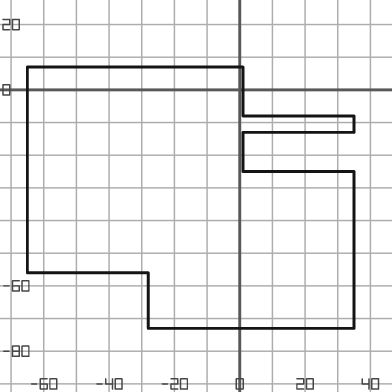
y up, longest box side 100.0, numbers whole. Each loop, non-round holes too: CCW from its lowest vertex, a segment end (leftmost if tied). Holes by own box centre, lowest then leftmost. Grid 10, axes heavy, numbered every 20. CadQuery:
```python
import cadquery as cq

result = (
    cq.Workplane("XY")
    .moveTo(-28.0, -73.0)
    .lineTo(35.0, -73.0)
    .lineTo(35.0, -25.0)
    .lineTo(1.0, -25.0)
    .lineTo(1.0, -13.0)
    .lineTo(35.0, -13.0)
    .lineTo(35.0, -8.0)
    .lineTo(1.0, -8.0)
    .lineTo(1.0, 7.0)
    .lineTo(-65.0, 7.0)
    .lineTo(-65.0, -56.0)
    .lineTo(-28.0, -56.0)
    .close()
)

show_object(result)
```